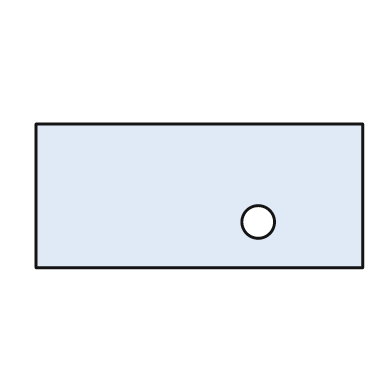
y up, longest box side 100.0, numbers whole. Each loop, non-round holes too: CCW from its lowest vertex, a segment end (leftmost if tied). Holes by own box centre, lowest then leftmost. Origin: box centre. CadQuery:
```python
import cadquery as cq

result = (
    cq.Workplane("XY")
    .moveTo(-50.0, -22.0)
    .lineTo(50.0, -22.0)
    .lineTo(50.0, 22.0)
    .lineTo(-50.0, 22.0)
    .close()
    .moveTo(18.0, -8.0)
    .circle(5.0)
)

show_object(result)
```